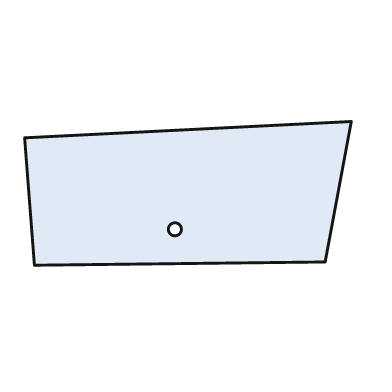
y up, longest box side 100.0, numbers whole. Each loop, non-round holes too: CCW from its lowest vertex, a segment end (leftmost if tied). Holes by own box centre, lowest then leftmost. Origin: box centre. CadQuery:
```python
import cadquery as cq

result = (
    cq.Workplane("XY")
    .moveTo(-47.0, -22.0)
    .lineTo(42.0, -21.0)
    .lineTo(50.0, 22.0)
    .lineTo(-50.0, 17.0)
    .close()
    .moveTo(-4.0, -11.0)
    .circle(2.0)
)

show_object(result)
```